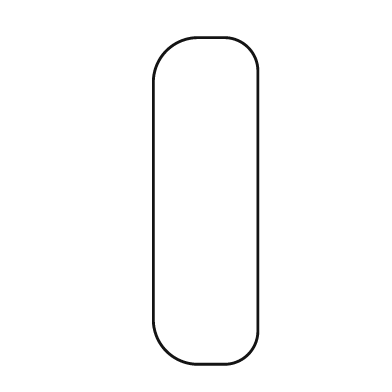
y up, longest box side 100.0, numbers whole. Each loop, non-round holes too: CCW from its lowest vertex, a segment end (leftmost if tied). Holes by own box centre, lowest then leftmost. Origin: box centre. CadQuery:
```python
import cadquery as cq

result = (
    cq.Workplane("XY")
    .moveTo(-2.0, -50.0)
    .lineTo(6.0, -50.0)
    .threePointArc((13.0, -47.0), (16.0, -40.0))
    .lineTo(16.0, 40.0)
    .threePointArc((13.0, 47.0), (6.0, 50.0))
    .lineTo(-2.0, 50.0)
    .threePointArc((-12.0, 46.0), (-16.0, 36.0))
    .lineTo(-16.0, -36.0)
    .threePointArc((-12.0, -46.0), (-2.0, -50.0))
    .close()
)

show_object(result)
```